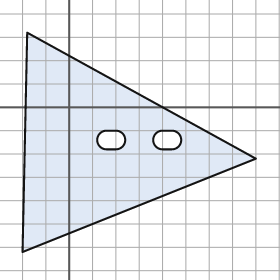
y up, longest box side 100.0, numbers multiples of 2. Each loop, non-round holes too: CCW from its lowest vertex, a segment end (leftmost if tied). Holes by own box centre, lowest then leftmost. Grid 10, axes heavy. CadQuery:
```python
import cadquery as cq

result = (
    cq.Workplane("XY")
    .moveTo(-20.0, -62.0)
    .lineTo(80.0, -22.0)
    .lineTo(-18.0, 32.0)
    .close()
    .moveTo(16.0, -18.0)
    .lineTo(20.0, -18.0)
    .threePointArc((24.0, -14.0), (20.0, -10.0))
    .lineTo(16.0, -10.0)
    .threePointArc((12.0, -14.0), (16.0, -18.0))
    .close()
    .moveTo(40.0, -18.0)
    .lineTo(44.0, -18.0)
    .threePointArc((48.0, -14.0), (44.0, -10.0))
    .lineTo(40.0, -10.0)
    .threePointArc((36.0, -14.0), (40.0, -18.0))
    .close()
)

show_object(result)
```